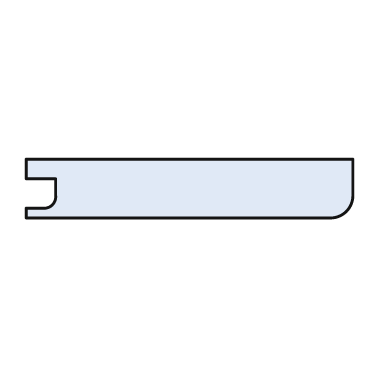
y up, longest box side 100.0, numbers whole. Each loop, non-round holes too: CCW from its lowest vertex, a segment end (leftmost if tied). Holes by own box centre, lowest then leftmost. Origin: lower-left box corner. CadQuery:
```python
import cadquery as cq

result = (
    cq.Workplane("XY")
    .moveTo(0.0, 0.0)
    .lineTo(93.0, 0.0)
    .threePointArc((98.0, 2.0), (100.0, 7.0))
    .lineTo(100.0, 18.0)
    .lineTo(0.0, 18.0)
    .lineTo(0.0, 12.0)
    .lineTo(9.0, 12.0)
    .lineTo(9.0, 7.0)
    .threePointArc((8.0, 4.0), (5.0, 3.0))
    .lineTo(0.0, 3.0)
    .close()
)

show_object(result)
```